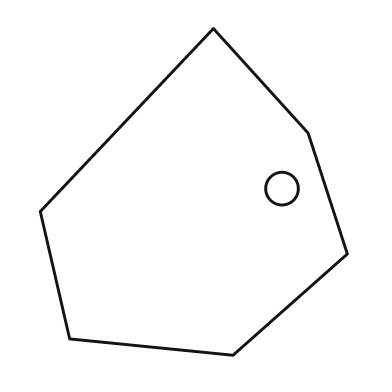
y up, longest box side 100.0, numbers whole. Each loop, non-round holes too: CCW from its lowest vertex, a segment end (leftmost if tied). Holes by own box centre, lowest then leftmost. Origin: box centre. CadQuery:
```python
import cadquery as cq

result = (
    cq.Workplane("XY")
    .moveTo(12.0, -50.0)
    .lineTo(47.0, -19.0)
    .lineTo(35.0, 18.0)
    .lineTo(6.0, 50.0)
    .lineTo(-47.0, -6.0)
    .lineTo(-38.0, -45.0)
    .close()
    .moveTo(27.0, 1.0)
    .circle(5.0)
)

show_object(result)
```